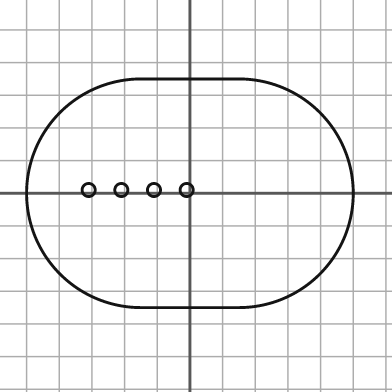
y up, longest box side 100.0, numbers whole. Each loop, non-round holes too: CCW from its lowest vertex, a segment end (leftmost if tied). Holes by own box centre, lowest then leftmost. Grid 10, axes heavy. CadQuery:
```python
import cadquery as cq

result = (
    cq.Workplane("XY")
    .moveTo(-15.0, -35.0)
    .lineTo(15.0, -35.0)
    .threePointArc((50.0, 0.0), (15.0, 35.0))
    .lineTo(-15.0, 35.0)
    .threePointArc((-50.0, 0.0), (-15.0, -35.0))
    .close()
    .moveTo(-31.0, 1.0)
    .circle(2.0)
    .moveTo(-21.0, 1.0)
    .circle(2.0)
    .moveTo(-11.0, 1.0)
    .circle(2.0)
    .moveTo(-1.0, 1.0)
    .circle(2.0)
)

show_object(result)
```